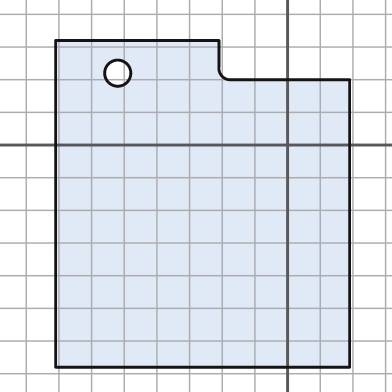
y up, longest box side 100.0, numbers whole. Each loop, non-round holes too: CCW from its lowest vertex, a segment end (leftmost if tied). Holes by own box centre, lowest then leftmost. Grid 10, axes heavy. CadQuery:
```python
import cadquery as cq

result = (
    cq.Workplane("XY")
    .moveTo(-71.0, -68.0)
    .lineTo(19.0, -68.0)
    .lineTo(19.0, 20.0)
    .lineTo(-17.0, 20.0)
    .threePointArc((-20.0, 21.0), (-21.0, 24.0))
    .lineTo(-21.0, 32.0)
    .lineTo(-71.0, 32.0)
    .close()
    .moveTo(-52.0, 22.0)
    .circle(4.0)
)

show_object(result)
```